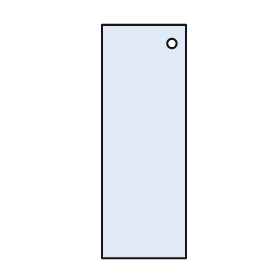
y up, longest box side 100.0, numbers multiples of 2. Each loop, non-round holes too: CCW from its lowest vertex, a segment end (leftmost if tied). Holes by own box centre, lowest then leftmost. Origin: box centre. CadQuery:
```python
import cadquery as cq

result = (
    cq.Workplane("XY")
    .moveTo(-18.0, -50.0)
    .lineTo(18.0, -50.0)
    .lineTo(18.0, 50.0)
    .lineTo(-18.0, 50.0)
    .close()
    .moveTo(12.0, 42.0)
    .circle(2.0)
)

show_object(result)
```